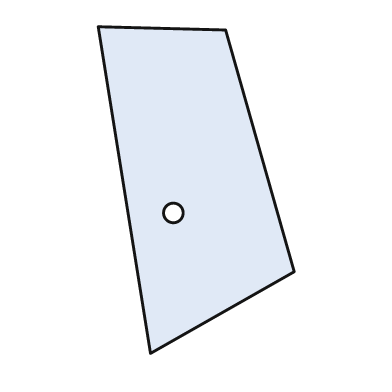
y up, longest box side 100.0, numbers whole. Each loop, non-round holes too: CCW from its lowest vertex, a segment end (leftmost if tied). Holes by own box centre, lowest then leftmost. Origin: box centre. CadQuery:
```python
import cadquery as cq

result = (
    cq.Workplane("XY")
    .moveTo(-14.0, -50.0)
    .lineTo(30.0, -25.0)
    .lineTo(9.0, 49.0)
    .lineTo(-30.0, 50.0)
    .close()
    .moveTo(-7.0, -7.0)
    .circle(3.0)
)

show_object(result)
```